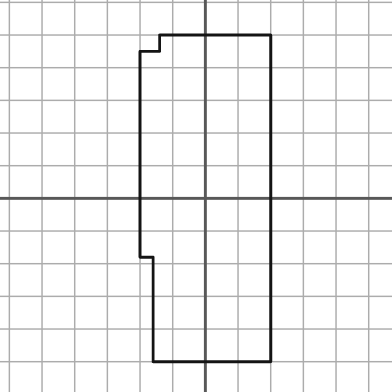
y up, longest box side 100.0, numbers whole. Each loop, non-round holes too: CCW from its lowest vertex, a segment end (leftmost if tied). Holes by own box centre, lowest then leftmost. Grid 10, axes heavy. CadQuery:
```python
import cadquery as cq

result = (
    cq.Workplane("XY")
    .moveTo(-16.0, -50.0)
    .lineTo(20.0, -50.0)
    .lineTo(20.0, 50.0)
    .lineTo(-14.0, 50.0)
    .lineTo(-14.0, 45.0)
    .lineTo(-20.0, 45.0)
    .lineTo(-20.0, -18.0)
    .lineTo(-16.0, -18.0)
    .close()
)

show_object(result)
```